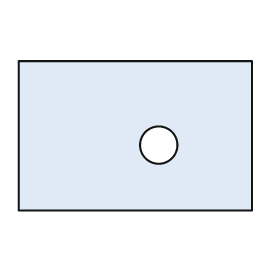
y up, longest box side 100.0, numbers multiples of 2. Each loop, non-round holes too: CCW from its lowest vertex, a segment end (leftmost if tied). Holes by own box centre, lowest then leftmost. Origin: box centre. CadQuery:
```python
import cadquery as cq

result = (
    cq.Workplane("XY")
    .moveTo(-50.0, -32.0)
    .lineTo(50.0, -32.0)
    .lineTo(50.0, 32.0)
    .lineTo(-50.0, 32.0)
    .close()
    .moveTo(10.0, -4.0)
    .circle(8.0)
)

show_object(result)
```